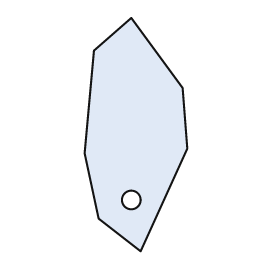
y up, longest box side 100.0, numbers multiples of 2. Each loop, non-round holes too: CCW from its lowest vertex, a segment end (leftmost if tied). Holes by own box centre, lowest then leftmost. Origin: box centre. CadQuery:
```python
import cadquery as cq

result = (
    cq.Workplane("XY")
    .moveTo(2.0, -50.0)
    .lineTo(22.0, -6.0)
    .lineTo(20.0, 20.0)
    .lineTo(-2.0, 50.0)
    .lineTo(-18.0, 36.0)
    .lineTo(-22.0, -8.0)
    .lineTo(-16.0, -36.0)
    .close()
    .moveTo(-2.0, -28.0)
    .circle(4.0)
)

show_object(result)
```